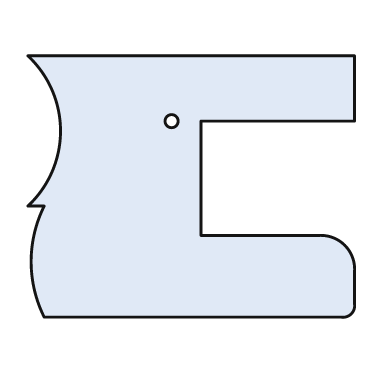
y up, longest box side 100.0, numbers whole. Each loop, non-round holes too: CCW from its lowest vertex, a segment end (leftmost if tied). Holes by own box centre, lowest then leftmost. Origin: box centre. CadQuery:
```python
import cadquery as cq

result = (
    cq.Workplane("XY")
    .moveTo(-45.0, -40.0)
    .lineTo(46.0, -40.0)
    .threePointArc((49.0, -39.0), (50.0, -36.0))
    .lineTo(50.0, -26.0)
    .threePointArc((47.0, -18.0), (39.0, -15.0))
    .lineTo(3.0, -15.0)
    .lineTo(3.0, 20.0)
    .lineTo(50.0, 20.0)
    .lineTo(50.0, 40.0)
    .lineTo(-50.0, 40.0)
    .threePointArc((-40.0, 17.0), (-50.0, -6.0))
    .lineTo(-45.0, -6.0)
    .threePointArc((-49.0, -23.0), (-45.0, -40.0))
    .close()
    .moveTo(-6.0, 20.0)
    .circle(2.0)
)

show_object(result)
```